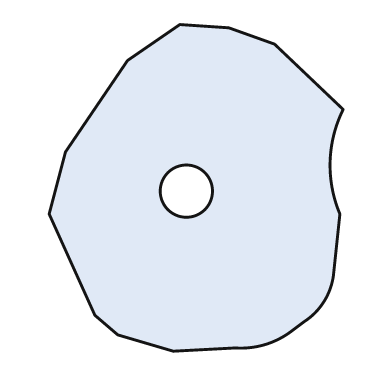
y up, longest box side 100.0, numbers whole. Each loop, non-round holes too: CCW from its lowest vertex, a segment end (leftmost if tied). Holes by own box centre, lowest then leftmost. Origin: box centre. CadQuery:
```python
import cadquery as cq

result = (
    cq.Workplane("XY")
    .moveTo(-7.0, -50.0)
    .lineTo(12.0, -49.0)
    .threePointArc((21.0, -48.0), (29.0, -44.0))
    .lineTo(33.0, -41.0)
    .threePointArc((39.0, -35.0), (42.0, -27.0))
    .lineTo(44.0, -8.0)
    .threePointArc((41.0, 8.0), (45.0, 24.0))
    .lineTo(24.0, 44.0)
    .lineTo(10.0, 49.0)
    .lineTo(-5.0, 50.0)
    .lineTo(-21.0, 39.0)
    .lineTo(-40.0, 11.0)
    .lineTo(-45.0, -8.0)
    .lineTo(-31.0, -39.0)
    .lineTo(-24.0, -45.0)
    .close()
    .moveTo(-3.0, -1.0)
    .circle(8.0)
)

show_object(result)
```